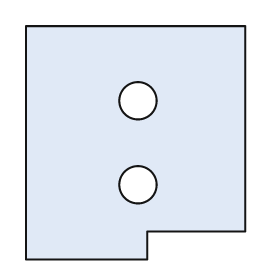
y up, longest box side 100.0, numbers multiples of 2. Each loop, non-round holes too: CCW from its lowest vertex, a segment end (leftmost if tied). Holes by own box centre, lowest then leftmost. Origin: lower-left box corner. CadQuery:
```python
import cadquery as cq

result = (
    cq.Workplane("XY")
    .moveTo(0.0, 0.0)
    .lineTo(52.0, 0.0)
    .lineTo(52.0, 12.0)
    .lineTo(94.0, 12.0)
    .lineTo(94.0, 100.0)
    .lineTo(0.0, 100.0)
    .close()
    .moveTo(48.0, 32.0)
    .circle(8.0)
    .moveTo(48.0, 68.0)
    .circle(8.0)
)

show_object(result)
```